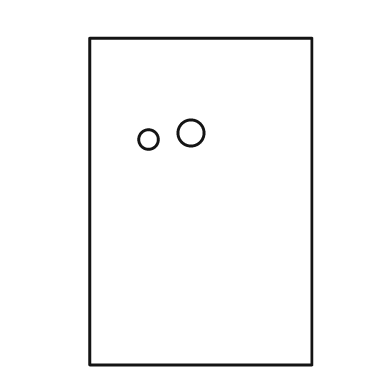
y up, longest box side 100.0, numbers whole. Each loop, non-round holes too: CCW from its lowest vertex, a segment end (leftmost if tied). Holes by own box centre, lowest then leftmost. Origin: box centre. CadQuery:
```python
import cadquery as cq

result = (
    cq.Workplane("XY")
    .moveTo(-34.0, -50.0)
    .lineTo(34.0, -50.0)
    .lineTo(34.0, 50.0)
    .lineTo(-34.0, 50.0)
    .close()
    .moveTo(-16.0, 19.0)
    .circle(3.0)
    .moveTo(-3.0, 21.0)
    .circle(4.0)
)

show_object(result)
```